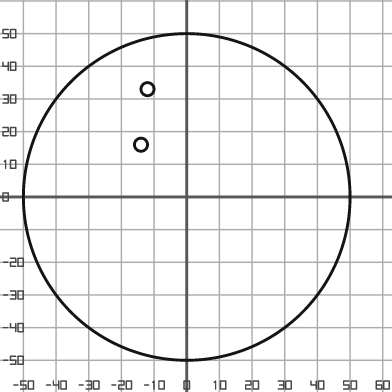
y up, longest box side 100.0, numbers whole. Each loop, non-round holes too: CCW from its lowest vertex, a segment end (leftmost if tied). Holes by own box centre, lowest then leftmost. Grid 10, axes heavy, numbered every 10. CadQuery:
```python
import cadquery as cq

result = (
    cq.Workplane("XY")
    .moveTo(0.0, 0.0)
    .circle(50.0)
    .moveTo(-14.0, 16.0)
    .circle(2.0)
    .moveTo(-12.0, 33.0)
    .circle(2.0)
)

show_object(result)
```